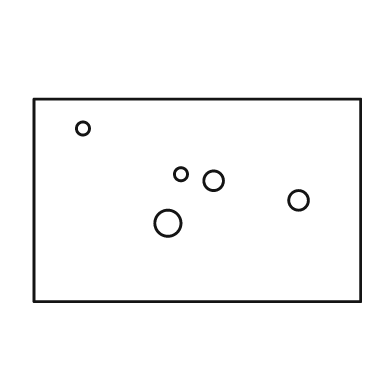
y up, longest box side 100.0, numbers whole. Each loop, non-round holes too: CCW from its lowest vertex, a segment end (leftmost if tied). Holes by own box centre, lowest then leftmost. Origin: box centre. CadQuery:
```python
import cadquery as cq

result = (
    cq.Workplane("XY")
    .moveTo(-50.0, -31.0)
    .lineTo(50.0, -31.0)
    .lineTo(50.0, 31.0)
    .lineTo(-50.0, 31.0)
    .close()
    .moveTo(-9.0, -7.0)
    .circle(4.0)
    .moveTo(31.0, 0.0)
    .circle(3.0)
    .moveTo(5.0, 6.0)
    .circle(3.0)
    .moveTo(-5.0, 8.0)
    .circle(2.0)
    .moveTo(-35.0, 22.0)
    .circle(2.0)
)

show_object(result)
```